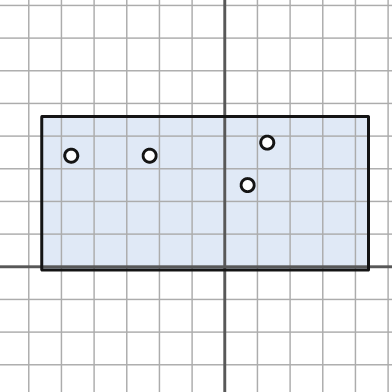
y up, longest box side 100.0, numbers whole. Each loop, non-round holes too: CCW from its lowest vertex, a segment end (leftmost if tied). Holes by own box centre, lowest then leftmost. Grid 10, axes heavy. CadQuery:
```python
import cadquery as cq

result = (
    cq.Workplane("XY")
    .moveTo(-56.0, -1.0)
    .lineTo(44.0, -1.0)
    .lineTo(44.0, 46.0)
    .lineTo(-56.0, 46.0)
    .close()
    .moveTo(7.0, 25.0)
    .circle(2.0)
    .moveTo(-47.0, 34.0)
    .circle(2.0)
    .moveTo(-23.0, 34.0)
    .circle(2.0)
    .moveTo(13.0, 38.0)
    .circle(2.0)
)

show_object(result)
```